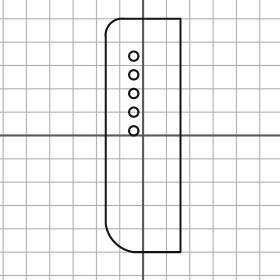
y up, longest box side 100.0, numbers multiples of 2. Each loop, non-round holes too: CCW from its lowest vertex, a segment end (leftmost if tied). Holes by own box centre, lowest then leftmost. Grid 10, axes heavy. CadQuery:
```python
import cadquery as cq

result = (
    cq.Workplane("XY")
    .moveTo(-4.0, -50.0)
    .lineTo(16.0, -50.0)
    .lineTo(16.0, 50.0)
    .lineTo(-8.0, 50.0)
    .threePointArc((-14.0, 48.0), (-16.0, 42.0))
    .lineTo(-16.0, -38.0)
    .threePointArc((-12.0, -46.0), (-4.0, -50.0))
    .close()
    .moveTo(-4.0, 2.0)
    .circle(2.0)
    .moveTo(-4.0, 10.0)
    .circle(2.0)
    .moveTo(-4.0, 18.0)
    .circle(2.0)
    .moveTo(-4.0, 26.0)
    .circle(2.0)
    .moveTo(-4.0, 34.0)
    .circle(2.0)
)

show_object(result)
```